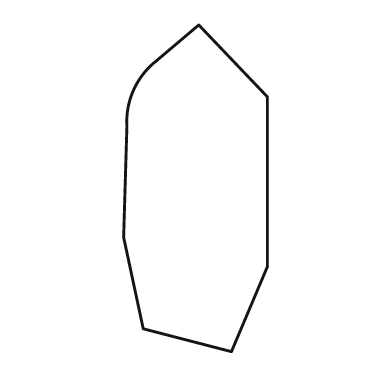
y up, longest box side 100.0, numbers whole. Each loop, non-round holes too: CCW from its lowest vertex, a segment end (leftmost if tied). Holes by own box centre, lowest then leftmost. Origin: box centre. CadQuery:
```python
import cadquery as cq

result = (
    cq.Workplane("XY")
    .moveTo(11.0, -50.0)
    .lineTo(22.0, -24.0)
    .lineTo(22.0, 28.0)
    .lineTo(1.0, 50.0)
    .lineTo(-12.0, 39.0)
    .threePointArc((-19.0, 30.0), (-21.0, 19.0))
    .lineTo(-22.0, -15.0)
    .lineTo(-16.0, -43.0)
    .close()
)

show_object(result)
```